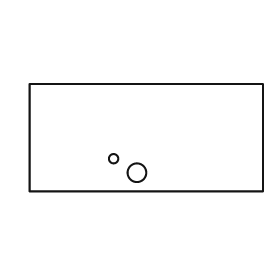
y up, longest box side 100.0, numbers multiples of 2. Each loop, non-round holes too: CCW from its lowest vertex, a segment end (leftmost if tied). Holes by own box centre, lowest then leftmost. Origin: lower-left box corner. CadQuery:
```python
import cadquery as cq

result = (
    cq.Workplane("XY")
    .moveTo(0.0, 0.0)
    .lineTo(100.0, 0.0)
    .lineTo(100.0, 46.0)
    .lineTo(0.0, 46.0)
    .close()
    .moveTo(46.0, 8.0)
    .circle(4.0)
    .moveTo(36.0, 14.0)
    .circle(2.0)
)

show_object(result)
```